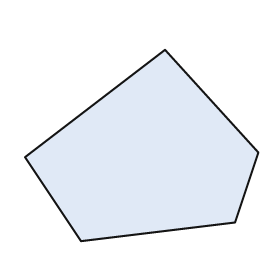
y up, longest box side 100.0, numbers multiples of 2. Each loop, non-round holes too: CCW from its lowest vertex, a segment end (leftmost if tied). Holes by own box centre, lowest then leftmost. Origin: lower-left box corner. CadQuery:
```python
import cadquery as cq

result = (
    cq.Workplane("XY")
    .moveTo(24.0, 0.0)
    .lineTo(90.0, 8.0)
    .lineTo(100.0, 38.0)
    .lineTo(60.0, 82.0)
    .lineTo(0.0, 36.0)
    .close()
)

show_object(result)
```